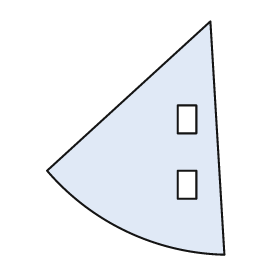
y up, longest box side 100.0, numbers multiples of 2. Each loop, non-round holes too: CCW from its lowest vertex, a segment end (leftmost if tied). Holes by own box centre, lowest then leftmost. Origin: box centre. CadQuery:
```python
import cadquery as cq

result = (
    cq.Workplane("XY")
    .moveTo(38.0, -50.0)
    .lineTo(32.0, 50.0)
    .lineTo(-38.0, -14.0)
    .threePointArc((-4.0, -40.0), (38.0, -50.0))
    .close()
    .moveTo(18.0, -26.0)
    .lineTo(26.0, -26.0)
    .lineTo(26.0, -14.0)
    .lineTo(18.0, -14.0)
    .close()
    .moveTo(18.0, 2.0)
    .lineTo(26.0, 2.0)
    .lineTo(26.0, 14.0)
    .lineTo(18.0, 14.0)
    .close()
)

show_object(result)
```